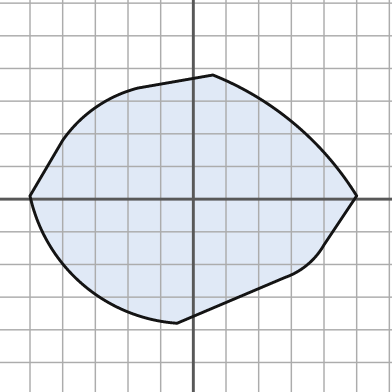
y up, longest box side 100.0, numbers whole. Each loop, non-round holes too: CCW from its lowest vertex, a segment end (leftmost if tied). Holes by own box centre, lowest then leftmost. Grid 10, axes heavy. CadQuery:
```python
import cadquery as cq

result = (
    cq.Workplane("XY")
    .moveTo(-5.0, -38.0)
    .lineTo(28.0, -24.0)
    .threePointArc((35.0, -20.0), (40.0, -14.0))
    .lineTo(50.0, 1.0)
    .threePointArc((31.0, 23.0), (6.0, 38.0))
    .lineTo(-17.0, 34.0)
    .threePointArc((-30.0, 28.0), (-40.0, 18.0))
    .lineTo(-50.0, 1.0)
    .threePointArc((-34.0, -26.0), (-5.0, -38.0))
    .close()
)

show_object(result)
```